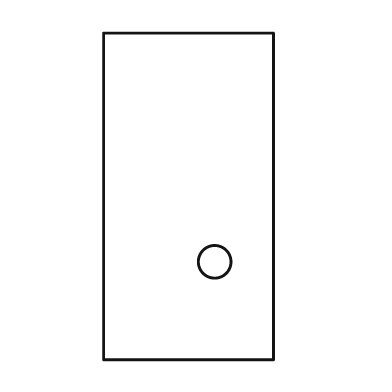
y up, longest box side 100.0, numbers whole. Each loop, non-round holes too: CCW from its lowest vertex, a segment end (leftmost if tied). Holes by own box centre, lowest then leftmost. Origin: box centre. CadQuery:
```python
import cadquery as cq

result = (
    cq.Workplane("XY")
    .moveTo(-26.0, -50.0)
    .lineTo(26.0, -50.0)
    .lineTo(26.0, 50.0)
    .lineTo(-26.0, 50.0)
    .close()
    .moveTo(8.0, -20.0)
    .circle(5.0)
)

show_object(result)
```